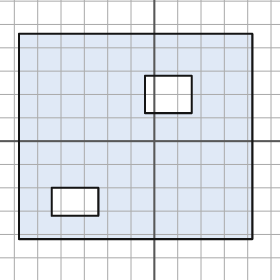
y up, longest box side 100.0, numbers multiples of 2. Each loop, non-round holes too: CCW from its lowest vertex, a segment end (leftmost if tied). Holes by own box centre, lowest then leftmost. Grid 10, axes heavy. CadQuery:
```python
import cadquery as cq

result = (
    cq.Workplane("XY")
    .moveTo(-58.0, -42.0)
    .lineTo(42.0, -42.0)
    .lineTo(42.0, 46.0)
    .lineTo(-58.0, 46.0)
    .close()
    .moveTo(-44.0, -32.0)
    .lineTo(-24.0, -32.0)
    .lineTo(-24.0, -20.0)
    .lineTo(-44.0, -20.0)
    .close()
    .moveTo(-4.0, 12.0)
    .lineTo(16.0, 12.0)
    .lineTo(16.0, 28.0)
    .lineTo(-4.0, 28.0)
    .close()
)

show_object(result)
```